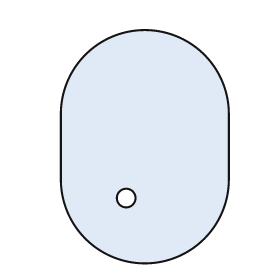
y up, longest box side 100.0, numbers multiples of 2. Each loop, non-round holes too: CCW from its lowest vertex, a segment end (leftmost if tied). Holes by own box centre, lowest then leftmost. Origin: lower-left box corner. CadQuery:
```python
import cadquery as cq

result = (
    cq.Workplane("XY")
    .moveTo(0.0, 36.0)
    .threePointArc((36.0, 0.0), (72.0, 36.0))
    .lineTo(72.0, 64.0)
    .threePointArc((36.0, 100.0), (0.0, 64.0))
    .close()
    .moveTo(28.0, 28.0)
    .circle(4.0)
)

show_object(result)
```